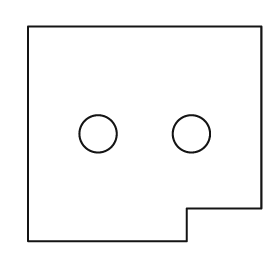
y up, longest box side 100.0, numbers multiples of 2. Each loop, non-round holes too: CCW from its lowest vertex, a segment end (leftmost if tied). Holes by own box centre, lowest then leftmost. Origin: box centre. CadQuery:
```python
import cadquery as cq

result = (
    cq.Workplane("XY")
    .moveTo(-50.0, -46.0)
    .lineTo(18.0, -46.0)
    .lineTo(18.0, -32.0)
    .lineTo(50.0, -32.0)
    .lineTo(50.0, 46.0)
    .lineTo(-50.0, 46.0)
    .close()
    .moveTo(-20.0, 0.0)
    .circle(8.0)
    .moveTo(20.0, 0.0)
    .circle(8.0)
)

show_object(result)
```